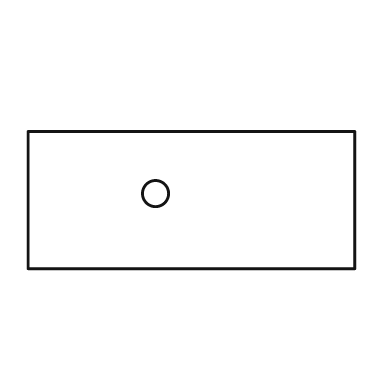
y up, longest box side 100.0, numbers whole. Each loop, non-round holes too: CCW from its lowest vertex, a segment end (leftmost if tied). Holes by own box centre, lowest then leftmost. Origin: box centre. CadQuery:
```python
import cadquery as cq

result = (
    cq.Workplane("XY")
    .moveTo(-50.0, -21.0)
    .lineTo(50.0, -21.0)
    .lineTo(50.0, 21.0)
    .lineTo(-50.0, 21.0)
    .close()
    .moveTo(-11.0, 2.0)
    .circle(4.0)
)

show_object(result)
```